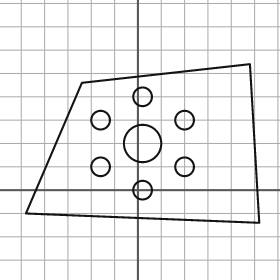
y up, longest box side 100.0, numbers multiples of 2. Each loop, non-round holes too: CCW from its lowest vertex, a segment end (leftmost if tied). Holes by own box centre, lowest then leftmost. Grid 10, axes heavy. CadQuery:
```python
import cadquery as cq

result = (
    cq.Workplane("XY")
    .moveTo(52.0, -14.0)
    .lineTo(48.0, 54.0)
    .lineTo(-24.0, 46.0)
    .lineTo(-48.0, -10.0)
    .close()
    .moveTo(2.0, 0.0)
    .circle(4.0)
    .moveTo(-16.0, 10.0)
    .circle(4.0)
    .moveTo(20.0, 10.0)
    .circle(4.0)
    .moveTo(2.0, 20.0)
    .circle(8.0)
    .moveTo(-16.0, 30.0)
    .circle(4.0)
    .moveTo(20.0, 30.0)
    .circle(4.0)
    .moveTo(2.0, 40.0)
    .circle(4.0)
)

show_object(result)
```